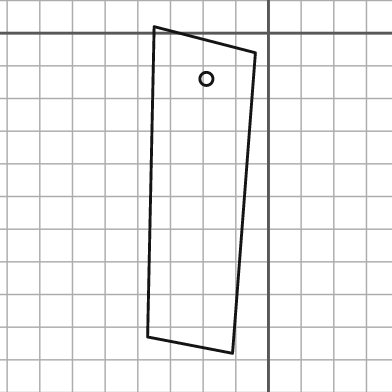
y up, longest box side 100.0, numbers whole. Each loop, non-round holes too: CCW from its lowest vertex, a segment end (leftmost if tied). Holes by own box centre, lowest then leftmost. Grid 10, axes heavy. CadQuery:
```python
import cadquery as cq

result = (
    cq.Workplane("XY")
    .moveTo(-11.0, -98.0)
    .lineTo(-4.0, -6.0)
    .lineTo(-35.0, 2.0)
    .lineTo(-37.0, -93.0)
    .close()
    .moveTo(-19.0, -14.0)
    .circle(2.0)
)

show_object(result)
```